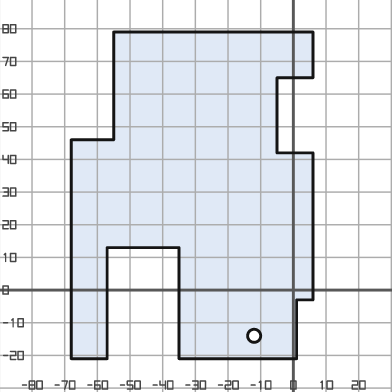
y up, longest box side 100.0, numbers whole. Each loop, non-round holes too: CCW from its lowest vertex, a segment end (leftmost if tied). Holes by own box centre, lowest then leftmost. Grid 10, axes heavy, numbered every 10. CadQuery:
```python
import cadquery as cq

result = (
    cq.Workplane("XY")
    .moveTo(-68.0, -21.0)
    .lineTo(-57.0, -21.0)
    .lineTo(-57.0, 13.0)
    .lineTo(-35.0, 13.0)
    .lineTo(-35.0, -21.0)
    .lineTo(1.0, -21.0)
    .lineTo(1.0, -3.0)
    .lineTo(6.0, -3.0)
    .lineTo(6.0, 42.0)
    .lineTo(-5.0, 42.0)
    .lineTo(-5.0, 65.0)
    .lineTo(6.0, 65.0)
    .lineTo(6.0, 79.0)
    .lineTo(-55.0, 79.0)
    .lineTo(-55.0, 46.0)
    .lineTo(-68.0, 46.0)
    .close()
    .moveTo(-12.0, -14.0)
    .circle(2.0)
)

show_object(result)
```